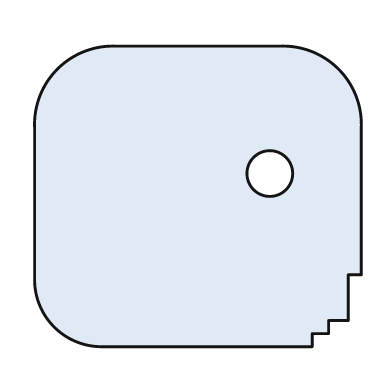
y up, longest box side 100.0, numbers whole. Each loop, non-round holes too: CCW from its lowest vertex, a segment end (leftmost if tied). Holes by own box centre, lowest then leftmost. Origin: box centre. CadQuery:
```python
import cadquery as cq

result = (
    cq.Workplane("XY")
    .moveTo(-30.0, -46.0)
    .lineTo(35.0, -46.0)
    .lineTo(35.0, -42.0)
    .lineTo(40.0, -42.0)
    .lineTo(40.0, -38.0)
    .lineTo(46.0, -38.0)
    .lineTo(46.0, -24.0)
    .lineTo(50.0, -24.0)
    .lineTo(50.0, 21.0)
    .threePointArc((43.0, 39.0), (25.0, 46.0))
    .lineTo(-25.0, 46.0)
    .threePointArc((-43.0, 39.0), (-50.0, 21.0))
    .lineTo(-50.0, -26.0)
    .threePointArc((-44.0, -40.0), (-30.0, -46.0))
    .close()
    .moveTo(22.0, 7.0)
    .circle(7.0)
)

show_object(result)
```